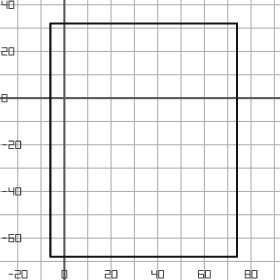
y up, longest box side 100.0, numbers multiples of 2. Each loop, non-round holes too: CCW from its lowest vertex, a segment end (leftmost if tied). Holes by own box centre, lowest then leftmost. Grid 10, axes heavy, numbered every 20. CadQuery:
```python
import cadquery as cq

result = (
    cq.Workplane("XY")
    .moveTo(-6.0, -68.0)
    .lineTo(74.0, -68.0)
    .lineTo(74.0, 32.0)
    .lineTo(-6.0, 32.0)
    .close()
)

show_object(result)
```